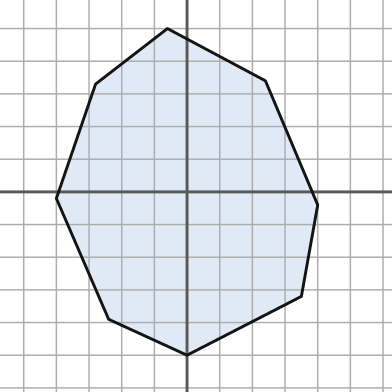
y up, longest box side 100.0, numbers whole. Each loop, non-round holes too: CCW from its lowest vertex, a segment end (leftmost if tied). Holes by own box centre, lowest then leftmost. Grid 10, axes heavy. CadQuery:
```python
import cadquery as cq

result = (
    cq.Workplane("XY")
    .moveTo(0.0, -50.0)
    .lineTo(35.0, -32.0)
    .lineTo(40.0, -4.0)
    .lineTo(24.0, 34.0)
    .lineTo(-6.0, 50.0)
    .lineTo(-28.0, 33.0)
    .lineTo(-40.0, -2.0)
    .lineTo(-24.0, -39.0)
    .close()
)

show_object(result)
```